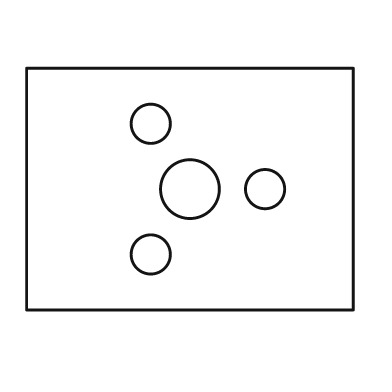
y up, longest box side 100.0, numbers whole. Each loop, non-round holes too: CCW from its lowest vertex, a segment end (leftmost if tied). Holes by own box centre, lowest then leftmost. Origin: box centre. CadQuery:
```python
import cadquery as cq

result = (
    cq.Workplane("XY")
    .moveTo(-50.0, -37.0)
    .lineTo(50.0, -37.0)
    .lineTo(50.0, 37.0)
    .lineTo(-50.0, 37.0)
    .close()
    .moveTo(-12.0, -20.0)
    .circle(6.0)
    .moveTo(0.0, 0.0)
    .circle(9.0)
    .moveTo(23.0, 0.0)
    .circle(6.0)
    .moveTo(-12.0, 20.0)
    .circle(6.0)
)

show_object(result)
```